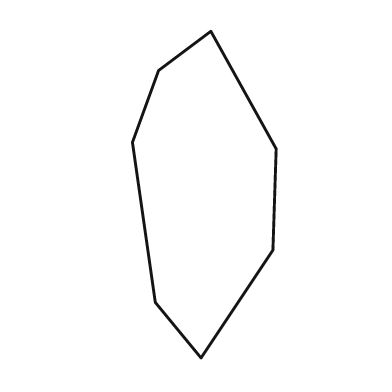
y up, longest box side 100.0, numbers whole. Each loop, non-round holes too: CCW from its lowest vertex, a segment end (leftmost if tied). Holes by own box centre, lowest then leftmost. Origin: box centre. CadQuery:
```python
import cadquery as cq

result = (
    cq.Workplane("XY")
    .moveTo(-1.0, -50.0)
    .lineTo(21.0, -17.0)
    .lineTo(22.0, 14.0)
    .lineTo(2.0, 50.0)
    .lineTo(-14.0, 38.0)
    .lineTo(-22.0, 16.0)
    .lineTo(-15.0, -33.0)
    .close()
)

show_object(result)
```